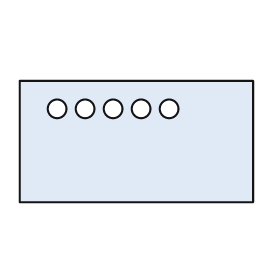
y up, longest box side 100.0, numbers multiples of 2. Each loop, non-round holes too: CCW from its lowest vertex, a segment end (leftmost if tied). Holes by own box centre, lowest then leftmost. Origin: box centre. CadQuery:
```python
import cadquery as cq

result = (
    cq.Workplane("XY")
    .moveTo(-50.0, -26.0)
    .lineTo(50.0, -26.0)
    .lineTo(50.0, 26.0)
    .lineTo(-50.0, 26.0)
    .close()
    .moveTo(-34.0, 14.0)
    .circle(4.0)
    .moveTo(-22.0, 14.0)
    .circle(4.0)
    .moveTo(-10.0, 14.0)
    .circle(4.0)
    .moveTo(2.0, 14.0)
    .circle(4.0)
    .moveTo(14.0, 14.0)
    .circle(4.0)
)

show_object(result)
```